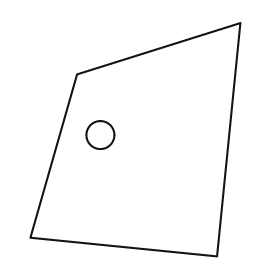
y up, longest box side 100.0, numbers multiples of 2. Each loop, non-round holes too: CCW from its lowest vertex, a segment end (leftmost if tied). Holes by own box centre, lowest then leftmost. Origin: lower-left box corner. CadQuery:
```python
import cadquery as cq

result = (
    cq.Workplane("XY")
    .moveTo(80.0, 0.0)
    .lineTo(90.0, 100.0)
    .lineTo(20.0, 78.0)
    .lineTo(0.0, 8.0)
    .close()
    .moveTo(30.0, 52.0)
    .circle(6.0)
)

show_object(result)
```